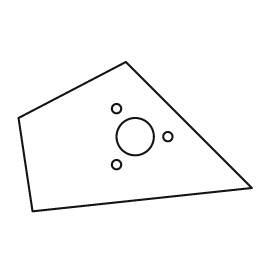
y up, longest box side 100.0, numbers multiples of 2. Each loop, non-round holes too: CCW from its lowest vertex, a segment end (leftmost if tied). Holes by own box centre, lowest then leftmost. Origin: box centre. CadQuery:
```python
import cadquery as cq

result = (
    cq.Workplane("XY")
    .moveTo(-44.0, -32.0)
    .lineTo(50.0, -22.0)
    .lineTo(-4.0, 32.0)
    .lineTo(-50.0, 8.0)
    .close()
    .moveTo(-8.0, -12.0)
    .circle(2.0)
    .moveTo(0.0, 0.0)
    .circle(8.0)
    .moveTo(14.0, 0.0)
    .circle(2.0)
    .moveTo(-8.0, 12.0)
    .circle(2.0)
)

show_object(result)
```